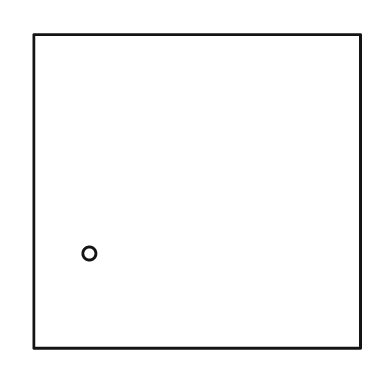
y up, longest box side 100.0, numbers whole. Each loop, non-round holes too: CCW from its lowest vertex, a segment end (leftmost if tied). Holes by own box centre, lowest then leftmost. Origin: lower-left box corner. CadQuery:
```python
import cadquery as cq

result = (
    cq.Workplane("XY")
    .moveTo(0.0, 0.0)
    .lineTo(100.0, 0.0)
    .lineTo(100.0, 96.0)
    .lineTo(0.0, 96.0)
    .close()
    .moveTo(17.0, 29.0)
    .circle(2.0)
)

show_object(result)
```